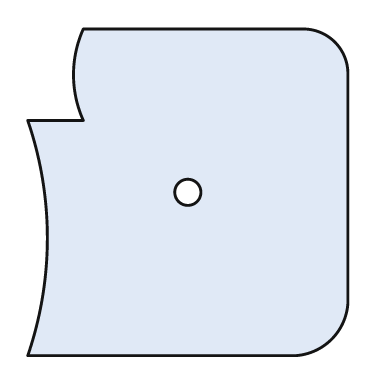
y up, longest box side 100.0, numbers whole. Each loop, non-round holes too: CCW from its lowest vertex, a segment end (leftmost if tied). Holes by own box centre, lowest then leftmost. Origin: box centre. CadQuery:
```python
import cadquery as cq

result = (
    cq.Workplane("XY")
    .moveTo(-49.0, -50.0)
    .lineTo(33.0, -50.0)
    .threePointArc((44.0, -45.0), (49.0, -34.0))
    .lineTo(49.0, 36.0)
    .threePointArc((45.0, 46.0), (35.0, 50.0))
    .lineTo(-32.0, 50.0)
    .threePointArc((-35.0, 36.0), (-32.0, 22.0))
    .lineTo(-49.0, 22.0)
    .threePointArc((-43.0, -14.0), (-49.0, -50.0))
    .close()
    .moveTo(0.0, 0.0)
    .circle(4.0)
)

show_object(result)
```